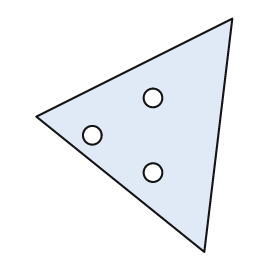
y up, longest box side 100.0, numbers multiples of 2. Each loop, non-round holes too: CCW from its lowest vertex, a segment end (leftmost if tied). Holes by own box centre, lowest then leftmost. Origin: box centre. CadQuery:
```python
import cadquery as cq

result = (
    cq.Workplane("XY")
    .moveTo(30.0, -50.0)
    .lineTo(42.0, 50.0)
    .lineTo(-42.0, 8.0)
    .close()
    .moveTo(8.0, -16.0)
    .circle(4.0)
    .moveTo(-18.0, 0.0)
    .circle(4.0)
    .moveTo(8.0, 16.0)
    .circle(4.0)
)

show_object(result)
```